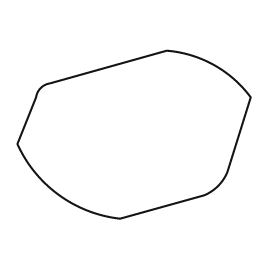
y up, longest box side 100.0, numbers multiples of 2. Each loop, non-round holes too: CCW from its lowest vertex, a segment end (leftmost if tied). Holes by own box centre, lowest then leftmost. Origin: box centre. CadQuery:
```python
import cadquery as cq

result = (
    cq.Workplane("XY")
    .moveTo(-6.0, -36.0)
    .lineTo(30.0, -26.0)
    .threePointArc((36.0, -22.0), (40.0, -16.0))
    .lineTo(50.0, 16.0)
    .threePointArc((34.0, 30.0), (14.0, 36.0))
    .lineTo(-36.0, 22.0)
    .threePointArc((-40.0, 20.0), (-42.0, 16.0))
    .lineTo(-50.0, -4.0)
    .threePointArc((-32.0, -26.0), (-6.0, -36.0))
    .close()
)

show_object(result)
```